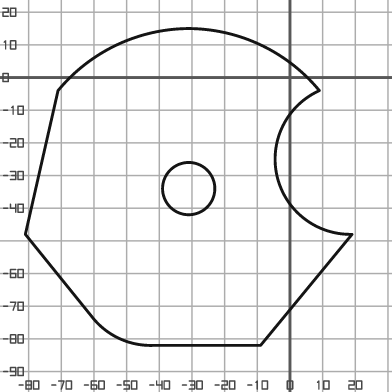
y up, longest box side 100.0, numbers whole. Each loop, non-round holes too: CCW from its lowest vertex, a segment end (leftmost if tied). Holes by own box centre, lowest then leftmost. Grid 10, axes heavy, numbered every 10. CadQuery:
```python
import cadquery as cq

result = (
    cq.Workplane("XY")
    .moveTo(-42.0, -82.0)
    .lineTo(-9.0, -82.0)
    .lineTo(19.0, -48.0)
    .threePointArc((-4.0, -30.0), (9.0, -4.0))
    .threePointArc((-9.0, 10.0), (-31.0, 15.0))
    .threePointArc((-53.0, 10.0), (-71.0, -4.0))
    .lineTo(-81.0, -48.0)
    .lineTo(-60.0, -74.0)
    .threePointArc((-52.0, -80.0), (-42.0, -82.0))
    .close()
    .moveTo(-31.0, -34.0)
    .circle(8.0)
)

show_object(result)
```